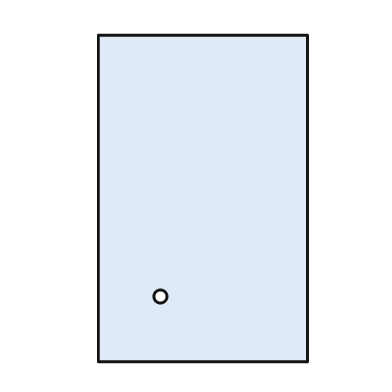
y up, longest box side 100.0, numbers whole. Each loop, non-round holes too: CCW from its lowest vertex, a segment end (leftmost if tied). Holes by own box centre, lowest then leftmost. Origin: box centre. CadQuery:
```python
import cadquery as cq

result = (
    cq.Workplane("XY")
    .moveTo(-32.0, -50.0)
    .lineTo(32.0, -50.0)
    .lineTo(32.0, 50.0)
    .lineTo(-32.0, 50.0)
    .close()
    .moveTo(-13.0, -30.0)
    .circle(2.0)
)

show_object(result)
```